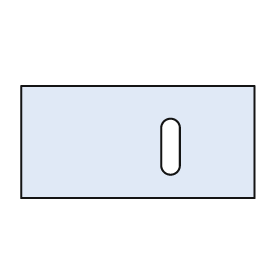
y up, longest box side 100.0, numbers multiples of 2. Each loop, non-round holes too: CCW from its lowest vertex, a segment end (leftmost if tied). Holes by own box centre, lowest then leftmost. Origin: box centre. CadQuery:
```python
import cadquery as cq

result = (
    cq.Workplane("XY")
    .moveTo(-50.0, -24.0)
    .lineTo(50.0, -24.0)
    .lineTo(50.0, 24.0)
    .lineTo(-50.0, 24.0)
    .close()
    .moveTo(10.0, -10.0)
    .threePointArc((14.0, -14.0), (18.0, -10.0))
    .lineTo(18.0, 6.0)
    .threePointArc((14.0, 10.0), (10.0, 6.0))
    .close()
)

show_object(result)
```